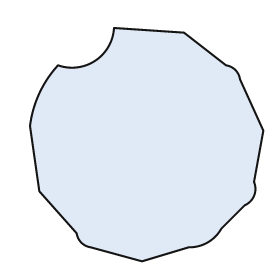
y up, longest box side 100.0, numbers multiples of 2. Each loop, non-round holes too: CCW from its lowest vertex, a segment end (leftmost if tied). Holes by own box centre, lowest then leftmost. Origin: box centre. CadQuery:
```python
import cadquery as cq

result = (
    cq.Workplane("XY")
    .moveTo(-2.0, -50.0)
    .lineTo(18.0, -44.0)
    .threePointArc((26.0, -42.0), (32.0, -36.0))
    .lineTo(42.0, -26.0)
    .threePointArc((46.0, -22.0), (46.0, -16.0))
    .lineTo(50.0, 6.0)
    .lineTo(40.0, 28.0)
    .threePointArc((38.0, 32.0), (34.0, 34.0))
    .lineTo(16.0, 48.0)
    .lineTo(-14.0, 50.0)
    .threePointArc((-22.0, 36.0), (-38.0, 34.0))
    .threePointArc((-46.0, 22.0), (-50.0, 8.0))
    .lineTo(-46.0, -20.0)
    .lineTo(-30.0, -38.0)
    .threePointArc((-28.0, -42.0), (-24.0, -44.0))
    .close()
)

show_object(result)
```